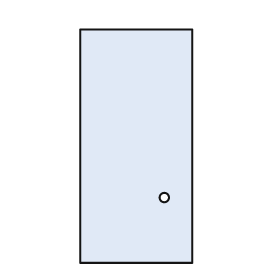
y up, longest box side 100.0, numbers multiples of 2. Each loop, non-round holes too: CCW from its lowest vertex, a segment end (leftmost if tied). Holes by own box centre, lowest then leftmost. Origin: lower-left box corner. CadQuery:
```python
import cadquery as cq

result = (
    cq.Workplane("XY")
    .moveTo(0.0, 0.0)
    .lineTo(48.0, 0.0)
    .lineTo(48.0, 100.0)
    .lineTo(0.0, 100.0)
    .close()
    .moveTo(36.0, 28.0)
    .circle(2.0)
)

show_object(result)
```